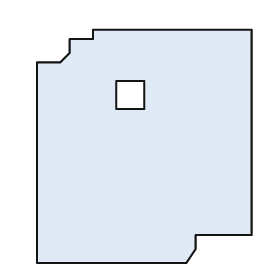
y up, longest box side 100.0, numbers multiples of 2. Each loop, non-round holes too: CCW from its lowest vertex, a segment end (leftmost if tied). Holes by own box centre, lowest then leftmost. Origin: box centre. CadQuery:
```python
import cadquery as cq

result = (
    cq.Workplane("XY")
    .moveTo(-46.0, -50.0)
    .lineTo(18.0, -50.0)
    .lineTo(22.0, -44.0)
    .lineTo(22.0, -38.0)
    .lineTo(46.0, -38.0)
    .lineTo(46.0, 50.0)
    .lineTo(-22.0, 50.0)
    .lineTo(-22.0, 46.0)
    .lineTo(-32.0, 46.0)
    .lineTo(-32.0, 40.0)
    .lineTo(-36.0, 36.0)
    .lineTo(-46.0, 36.0)
    .close()
    .moveTo(-12.0, 16.0)
    .lineTo(0.0, 16.0)
    .lineTo(0.0, 28.0)
    .lineTo(-12.0, 28.0)
    .close()
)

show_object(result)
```